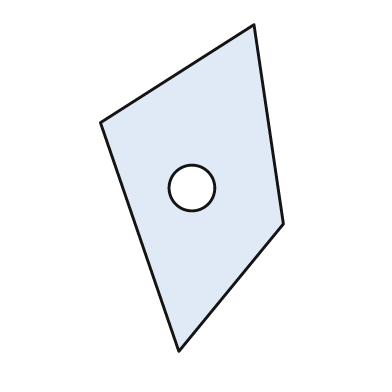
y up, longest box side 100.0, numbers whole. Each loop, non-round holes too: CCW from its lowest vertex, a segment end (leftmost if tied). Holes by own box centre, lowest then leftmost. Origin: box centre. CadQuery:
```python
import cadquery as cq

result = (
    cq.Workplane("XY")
    .moveTo(-4.0, -50.0)
    .lineTo(28.0, -11.0)
    .lineTo(19.0, 50.0)
    .lineTo(-28.0, 20.0)
    .close()
    .moveTo(0.0, 0.0)
    .circle(7.0)
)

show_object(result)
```